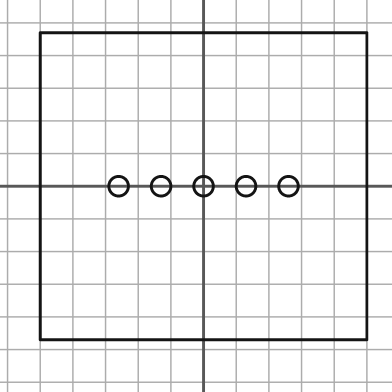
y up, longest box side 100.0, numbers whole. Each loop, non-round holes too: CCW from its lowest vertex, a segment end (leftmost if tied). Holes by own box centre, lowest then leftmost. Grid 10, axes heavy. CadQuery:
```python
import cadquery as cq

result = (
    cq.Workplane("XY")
    .moveTo(-50.0, -47.0)
    .lineTo(50.0, -47.0)
    .lineTo(50.0, 47.0)
    .lineTo(-50.0, 47.0)
    .close()
    .moveTo(-26.0, 0.0)
    .circle(3.0)
    .moveTo(-13.0, 0.0)
    .circle(3.0)
    .moveTo(0.0, 0.0)
    .circle(3.0)
    .moveTo(13.0, 0.0)
    .circle(3.0)
    .moveTo(26.0, 0.0)
    .circle(3.0)
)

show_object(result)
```